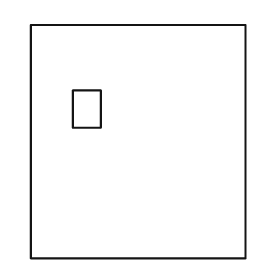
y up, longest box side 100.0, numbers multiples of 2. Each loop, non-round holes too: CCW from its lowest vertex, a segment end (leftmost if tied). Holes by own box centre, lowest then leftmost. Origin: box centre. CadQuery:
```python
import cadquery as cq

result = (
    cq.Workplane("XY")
    .moveTo(-46.0, -50.0)
    .lineTo(46.0, -50.0)
    .lineTo(46.0, 50.0)
    .lineTo(-46.0, 50.0)
    .close()
    .moveTo(-28.0, 6.0)
    .lineTo(-16.0, 6.0)
    .lineTo(-16.0, 22.0)
    .lineTo(-28.0, 22.0)
    .close()
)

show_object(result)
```